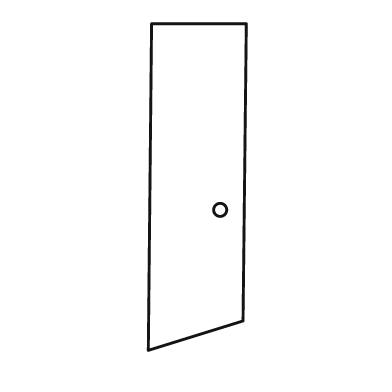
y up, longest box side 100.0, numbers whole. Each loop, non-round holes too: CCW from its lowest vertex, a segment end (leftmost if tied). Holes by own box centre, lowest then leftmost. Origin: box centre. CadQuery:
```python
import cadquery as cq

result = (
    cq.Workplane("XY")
    .moveTo(-15.0, -50.0)
    .lineTo(14.0, -41.0)
    .lineTo(15.0, 50.0)
    .lineTo(-14.0, 50.0)
    .close()
    .moveTo(7.0, -7.0)
    .circle(2.0)
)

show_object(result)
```